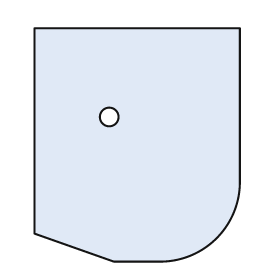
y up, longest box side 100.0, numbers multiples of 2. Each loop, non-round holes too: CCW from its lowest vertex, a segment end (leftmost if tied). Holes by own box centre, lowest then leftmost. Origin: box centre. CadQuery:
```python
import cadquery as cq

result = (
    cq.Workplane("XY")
    .moveTo(-10.0, -50.0)
    .lineTo(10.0, -50.0)
    .threePointArc((34.0, -40.0), (44.0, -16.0))
    .lineTo(44.0, 50.0)
    .lineTo(-44.0, 50.0)
    .lineTo(-44.0, -38.0)
    .close()
    .moveTo(-12.0, 12.0)
    .circle(4.0)
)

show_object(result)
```